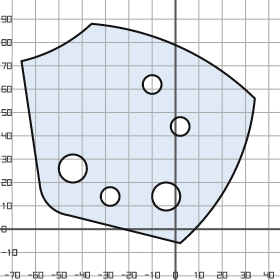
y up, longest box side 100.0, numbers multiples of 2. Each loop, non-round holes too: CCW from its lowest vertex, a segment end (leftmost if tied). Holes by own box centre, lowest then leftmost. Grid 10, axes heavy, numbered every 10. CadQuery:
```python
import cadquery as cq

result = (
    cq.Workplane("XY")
    .moveTo(2.0, -6.0)
    .threePointArc((24.0, 22.0), (34.0, 56.0))
    .threePointArc((2.0, 78.0), (-36.0, 88.0))
    .threePointArc((-50.0, 78.0), (-66.0, 72.0))
    .lineTo(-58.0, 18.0)
    .threePointArc((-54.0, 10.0), (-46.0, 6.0))
    .close()
    .moveTo(-28.0, 14.0)
    .circle(4.0)
    .moveTo(-4.0, 14.0)
    .circle(6.0)
    .moveTo(-44.0, 26.0)
    .circle(6.0)
    .moveTo(2.0, 44.0)
    .circle(4.0)
    .moveTo(-10.0, 62.0)
    .circle(4.0)
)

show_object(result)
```